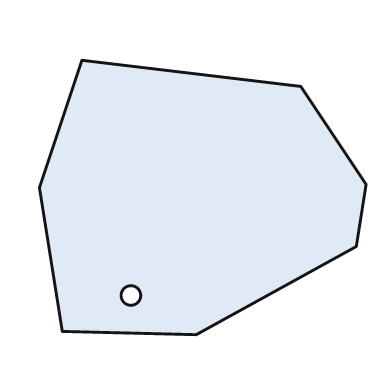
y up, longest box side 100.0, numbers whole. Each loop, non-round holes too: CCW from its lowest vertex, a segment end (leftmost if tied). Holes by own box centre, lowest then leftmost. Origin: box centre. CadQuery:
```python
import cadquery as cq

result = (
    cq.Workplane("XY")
    .moveTo(-2.0, -42.0)
    .lineTo(47.0, -15.0)
    .lineTo(50.0, 4.0)
    .lineTo(30.0, 34.0)
    .lineTo(-37.0, 42.0)
    .lineTo(-50.0, 3.0)
    .lineTo(-43.0, -41.0)
    .close()
    .moveTo(-22.0, -30.0)
    .circle(3.0)
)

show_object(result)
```